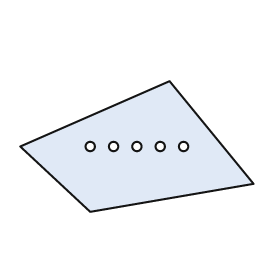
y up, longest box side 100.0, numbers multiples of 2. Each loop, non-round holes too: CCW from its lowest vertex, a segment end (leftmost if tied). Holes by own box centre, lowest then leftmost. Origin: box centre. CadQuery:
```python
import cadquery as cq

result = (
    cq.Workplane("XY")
    .moveTo(-20.0, -28.0)
    .lineTo(50.0, -16.0)
    .lineTo(14.0, 28.0)
    .lineTo(-50.0, 0.0)
    .close()
    .moveTo(-20.0, 0.0)
    .circle(2.0)
    .moveTo(-10.0, 0.0)
    .circle(2.0)
    .moveTo(0.0, 0.0)
    .circle(2.0)
    .moveTo(10.0, 0.0)
    .circle(2.0)
    .moveTo(20.0, 0.0)
    .circle(2.0)
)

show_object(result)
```